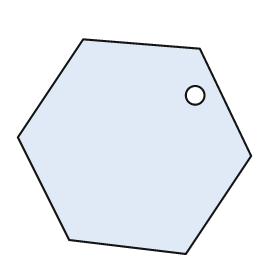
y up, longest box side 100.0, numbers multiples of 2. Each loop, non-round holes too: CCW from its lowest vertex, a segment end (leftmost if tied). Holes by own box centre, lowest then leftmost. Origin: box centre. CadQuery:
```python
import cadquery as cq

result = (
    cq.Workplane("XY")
    .moveTo(22.0, -46.0)
    .lineTo(50.0, -4.0)
    .lineTo(28.0, 42.0)
    .lineTo(-22.0, 46.0)
    .lineTo(-50.0, 4.0)
    .lineTo(-28.0, -40.0)
    .close()
    .moveTo(26.0, 22.0)
    .circle(4.0)
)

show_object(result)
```